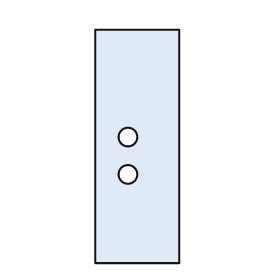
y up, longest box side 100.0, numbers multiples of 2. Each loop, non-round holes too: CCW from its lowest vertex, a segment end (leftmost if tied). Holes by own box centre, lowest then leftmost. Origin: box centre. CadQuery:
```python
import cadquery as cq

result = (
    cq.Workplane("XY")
    .moveTo(-18.0, -50.0)
    .lineTo(18.0, -50.0)
    .lineTo(18.0, 50.0)
    .lineTo(-18.0, 50.0)
    .close()
    .moveTo(-4.0, -12.0)
    .circle(4.0)
    .moveTo(-4.0, 4.0)
    .circle(4.0)
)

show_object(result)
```